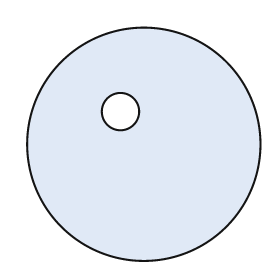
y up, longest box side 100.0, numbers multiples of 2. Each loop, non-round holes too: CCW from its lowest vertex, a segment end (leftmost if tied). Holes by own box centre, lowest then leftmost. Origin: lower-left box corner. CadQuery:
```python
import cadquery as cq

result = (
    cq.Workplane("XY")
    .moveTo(50.0, 50.0)
    .circle(50.0)
    .moveTo(40.0, 64.0)
    .circle(8.0)
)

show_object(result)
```